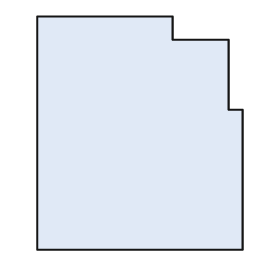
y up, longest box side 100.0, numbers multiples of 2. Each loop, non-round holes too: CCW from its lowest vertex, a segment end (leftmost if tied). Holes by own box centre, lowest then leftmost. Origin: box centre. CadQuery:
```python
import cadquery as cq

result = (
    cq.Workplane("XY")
    .moveTo(-44.0, -50.0)
    .lineTo(44.0, -50.0)
    .lineTo(44.0, 10.0)
    .lineTo(38.0, 10.0)
    .lineTo(38.0, 40.0)
    .lineTo(14.0, 40.0)
    .lineTo(14.0, 50.0)
    .lineTo(-44.0, 50.0)
    .close()
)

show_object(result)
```